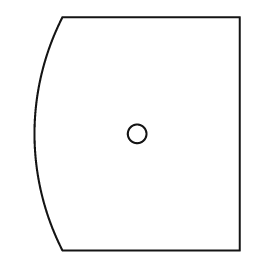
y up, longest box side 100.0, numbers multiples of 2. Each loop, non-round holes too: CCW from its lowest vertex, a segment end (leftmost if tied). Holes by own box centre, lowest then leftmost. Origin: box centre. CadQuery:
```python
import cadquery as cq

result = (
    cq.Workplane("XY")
    .moveTo(-32.0, -50.0)
    .lineTo(44.0, -50.0)
    .lineTo(44.0, 50.0)
    .lineTo(-32.0, 50.0)
    .threePointArc((-44.0, 0.0), (-32.0, -50.0))
    .close()
    .moveTo(0.0, 0.0)
    .circle(4.0)
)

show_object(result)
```